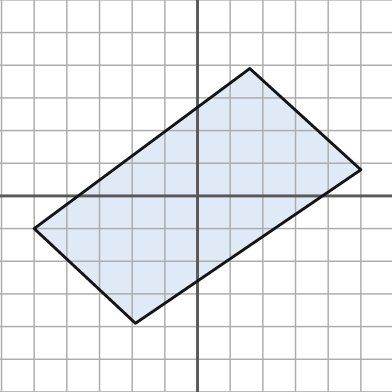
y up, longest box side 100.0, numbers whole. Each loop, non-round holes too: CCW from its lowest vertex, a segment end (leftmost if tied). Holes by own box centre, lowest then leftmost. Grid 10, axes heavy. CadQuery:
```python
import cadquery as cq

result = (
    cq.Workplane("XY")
    .moveTo(-19.0, -39.0)
    .lineTo(50.0, 8.0)
    .lineTo(16.0, 39.0)
    .lineTo(-50.0, -10.0)
    .close()
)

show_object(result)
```